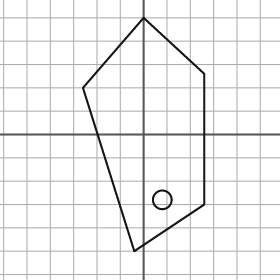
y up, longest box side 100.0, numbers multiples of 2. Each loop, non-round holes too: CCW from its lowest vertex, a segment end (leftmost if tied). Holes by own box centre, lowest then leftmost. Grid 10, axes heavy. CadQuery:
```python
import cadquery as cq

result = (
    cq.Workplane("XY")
    .moveTo(-4.0, -50.0)
    .lineTo(26.0, -30.0)
    .lineTo(26.0, 26.0)
    .lineTo(0.0, 50.0)
    .lineTo(-26.0, 20.0)
    .close()
    .moveTo(8.0, -28.0)
    .circle(4.0)
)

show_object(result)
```